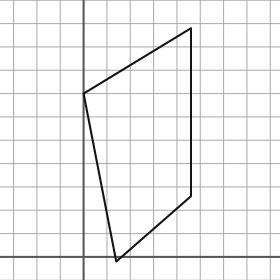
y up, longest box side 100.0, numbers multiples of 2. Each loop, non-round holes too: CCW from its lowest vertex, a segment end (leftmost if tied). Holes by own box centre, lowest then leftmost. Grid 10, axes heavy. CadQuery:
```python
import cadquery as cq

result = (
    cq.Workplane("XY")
    .moveTo(14.0, -2.0)
    .lineTo(46.0, 26.0)
    .lineTo(46.0, 98.0)
    .lineTo(0.0, 70.0)
    .close()
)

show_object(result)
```